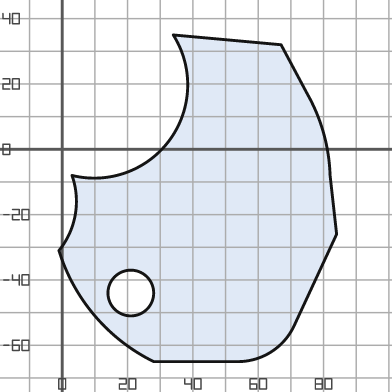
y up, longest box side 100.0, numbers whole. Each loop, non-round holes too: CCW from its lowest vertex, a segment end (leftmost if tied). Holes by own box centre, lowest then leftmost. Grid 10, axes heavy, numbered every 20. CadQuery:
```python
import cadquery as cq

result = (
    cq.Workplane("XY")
    .moveTo(28.0, -65.0)
    .lineTo(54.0, -65.0)
    .threePointArc((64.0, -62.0), (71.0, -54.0))
    .lineTo(84.0, -26.0)
    .lineTo(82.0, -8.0)
    .threePointArc((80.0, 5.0), (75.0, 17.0))
    .lineTo(67.0, 32.0)
    .lineTo(34.0, 35.0)
    .threePointArc((33.0, 3.0), (3.0, -8.0))
    .threePointArc((4.0, -20.0), (-1.0, -31.0))
    .threePointArc((10.0, -51.0), (28.0, -65.0))
    .close()
    .moveTo(21.0, -44.0)
    .circle(7.0)
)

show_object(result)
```